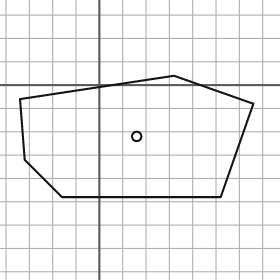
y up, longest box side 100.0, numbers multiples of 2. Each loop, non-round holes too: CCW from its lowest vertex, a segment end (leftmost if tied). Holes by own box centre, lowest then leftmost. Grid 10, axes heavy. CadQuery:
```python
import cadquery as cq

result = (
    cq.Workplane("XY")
    .moveTo(-16.0, -48.0)
    .lineTo(52.0, -48.0)
    .lineTo(66.0, -8.0)
    .lineTo(32.0, 4.0)
    .lineTo(-34.0, -6.0)
    .lineTo(-32.0, -32.0)
    .close()
    .moveTo(16.0, -22.0)
    .circle(2.0)
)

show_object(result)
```